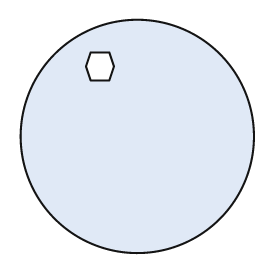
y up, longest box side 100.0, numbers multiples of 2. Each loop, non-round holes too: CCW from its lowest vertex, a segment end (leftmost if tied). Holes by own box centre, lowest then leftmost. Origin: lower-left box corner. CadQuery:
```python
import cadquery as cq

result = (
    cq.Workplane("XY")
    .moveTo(50.0, 50.0)
    .circle(50.0)
    .moveTo(30.0, 74.0)
    .lineTo(38.0, 74.0)
    .lineTo(40.0, 80.0)
    .lineTo(38.0, 86.0)
    .lineTo(30.0, 86.0)
    .lineTo(28.0, 80.0)
    .close()
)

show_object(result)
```